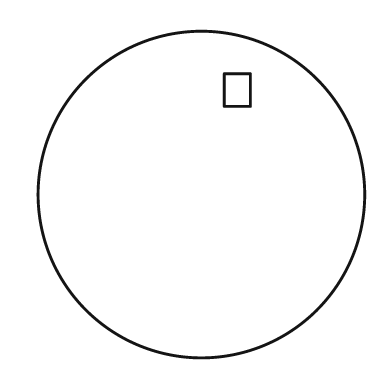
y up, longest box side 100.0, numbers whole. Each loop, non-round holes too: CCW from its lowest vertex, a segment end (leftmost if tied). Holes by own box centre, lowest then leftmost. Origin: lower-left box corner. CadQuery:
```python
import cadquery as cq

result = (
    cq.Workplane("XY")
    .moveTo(50.0, 50.0)
    .circle(50.0)
    .moveTo(57.0, 77.0)
    .lineTo(65.0, 77.0)
    .lineTo(65.0, 87.0)
    .lineTo(57.0, 87.0)
    .close()
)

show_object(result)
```